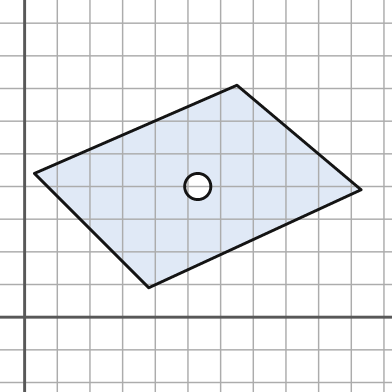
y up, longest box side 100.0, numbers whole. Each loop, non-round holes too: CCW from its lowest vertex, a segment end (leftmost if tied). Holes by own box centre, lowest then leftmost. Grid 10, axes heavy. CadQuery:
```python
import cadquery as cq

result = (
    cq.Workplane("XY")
    .moveTo(38.0, 9.0)
    .lineTo(103.0, 39.0)
    .lineTo(65.0, 71.0)
    .lineTo(3.0, 44.0)
    .close()
    .moveTo(53.0, 40.0)
    .circle(4.0)
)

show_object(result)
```